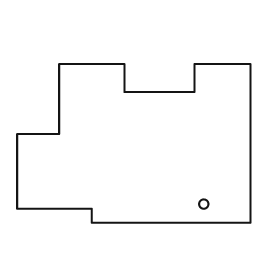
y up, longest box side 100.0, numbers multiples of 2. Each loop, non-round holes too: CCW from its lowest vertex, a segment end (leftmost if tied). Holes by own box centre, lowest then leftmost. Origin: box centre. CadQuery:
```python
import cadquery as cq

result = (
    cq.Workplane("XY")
    .moveTo(-18.0, -34.0)
    .lineTo(50.0, -34.0)
    .lineTo(50.0, 34.0)
    .lineTo(26.0, 34.0)
    .lineTo(26.0, 22.0)
    .lineTo(-4.0, 22.0)
    .lineTo(-4.0, 34.0)
    .lineTo(-32.0, 34.0)
    .lineTo(-32.0, 4.0)
    .lineTo(-50.0, 4.0)
    .lineTo(-50.0, -28.0)
    .lineTo(-18.0, -28.0)
    .close()
    .moveTo(30.0, -26.0)
    .circle(2.0)
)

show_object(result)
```